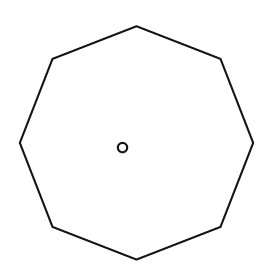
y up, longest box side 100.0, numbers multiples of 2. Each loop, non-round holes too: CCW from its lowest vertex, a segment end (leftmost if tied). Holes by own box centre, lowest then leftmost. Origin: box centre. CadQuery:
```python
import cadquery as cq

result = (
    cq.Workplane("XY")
    .moveTo(0.0, -50.0)
    .lineTo(36.0, -36.0)
    .lineTo(50.0, 0.0)
    .lineTo(36.0, 36.0)
    .lineTo(0.0, 50.0)
    .lineTo(-36.0, 36.0)
    .lineTo(-50.0, 0.0)
    .lineTo(-36.0, -36.0)
    .close()
    .moveTo(-6.0, -2.0)
    .circle(2.0)
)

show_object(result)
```